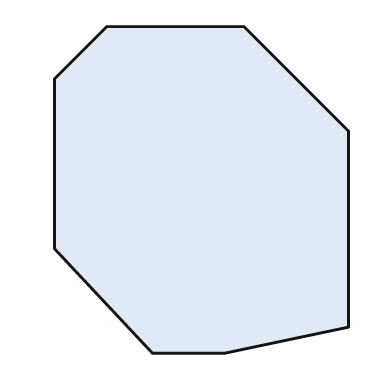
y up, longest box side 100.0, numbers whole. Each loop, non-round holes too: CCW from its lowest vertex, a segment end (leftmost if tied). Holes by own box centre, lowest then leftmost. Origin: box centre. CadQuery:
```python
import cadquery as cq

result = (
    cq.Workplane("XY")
    .moveTo(-15.0, -50.0)
    .lineTo(7.0, -50.0)
    .lineTo(45.0, -42.0)
    .lineTo(45.0, 18.0)
    .lineTo(13.0, 50.0)
    .lineTo(-29.0, 50.0)
    .lineTo(-45.0, 34.0)
    .lineTo(-45.0, -18.0)
    .close()
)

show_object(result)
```